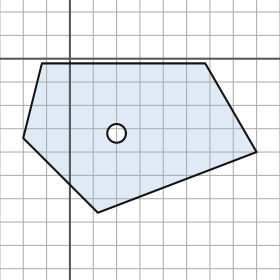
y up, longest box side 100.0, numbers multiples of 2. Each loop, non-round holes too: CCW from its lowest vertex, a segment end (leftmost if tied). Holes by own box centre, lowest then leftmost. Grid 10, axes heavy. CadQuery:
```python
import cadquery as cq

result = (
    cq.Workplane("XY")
    .moveTo(12.0, -66.0)
    .lineTo(80.0, -40.0)
    .lineTo(58.0, -2.0)
    .lineTo(-12.0, -2.0)
    .lineTo(-20.0, -34.0)
    .close()
    .moveTo(20.0, -32.0)
    .circle(4.0)
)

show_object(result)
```